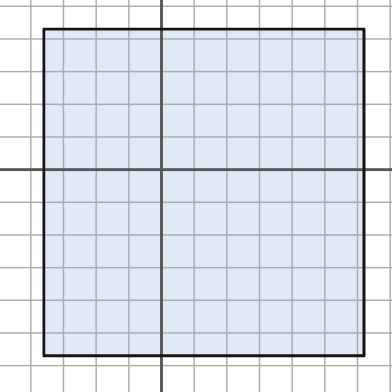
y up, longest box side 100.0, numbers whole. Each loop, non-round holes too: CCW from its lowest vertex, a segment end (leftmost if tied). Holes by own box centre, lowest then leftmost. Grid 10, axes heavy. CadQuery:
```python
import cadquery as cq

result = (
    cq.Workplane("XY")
    .moveTo(-36.0, -57.0)
    .lineTo(62.0, -57.0)
    .lineTo(62.0, 43.0)
    .lineTo(-36.0, 43.0)
    .close()
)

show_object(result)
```